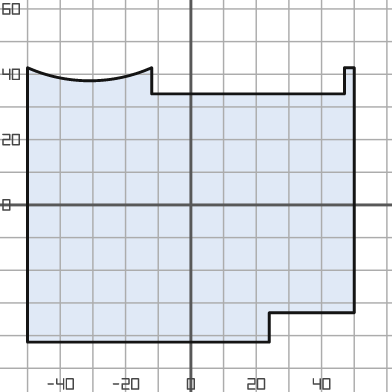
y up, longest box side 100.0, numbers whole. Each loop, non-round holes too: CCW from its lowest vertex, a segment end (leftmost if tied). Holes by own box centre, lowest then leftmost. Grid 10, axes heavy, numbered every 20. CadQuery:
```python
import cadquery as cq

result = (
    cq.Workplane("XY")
    .moveTo(-50.0, -42.0)
    .lineTo(24.0, -42.0)
    .lineTo(24.0, -33.0)
    .lineTo(50.0, -33.0)
    .lineTo(50.0, 42.0)
    .lineTo(47.0, 42.0)
    .lineTo(47.0, 34.0)
    .lineTo(-12.0, 34.0)
    .lineTo(-12.0, 42.0)
    .threePointArc((-31.0, 38.0), (-50.0, 42.0))
    .close()
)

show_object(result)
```